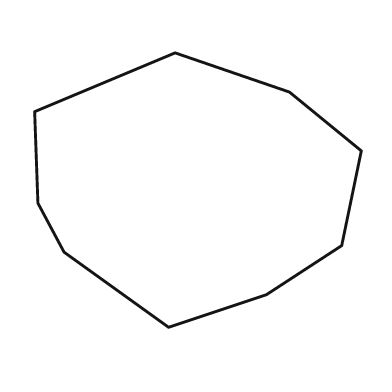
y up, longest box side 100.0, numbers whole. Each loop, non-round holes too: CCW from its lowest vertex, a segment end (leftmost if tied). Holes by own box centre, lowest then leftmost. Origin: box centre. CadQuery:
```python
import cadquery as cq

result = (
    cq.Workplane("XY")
    .moveTo(-9.0, -42.0)
    .lineTo(21.0, -32.0)
    .lineTo(44.0, -17.0)
    .lineTo(50.0, 12.0)
    .lineTo(28.0, 30.0)
    .lineTo(-7.0, 42.0)
    .lineTo(-50.0, 24.0)
    .lineTo(-49.0, -4.0)
    .lineTo(-41.0, -19.0)
    .close()
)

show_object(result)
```